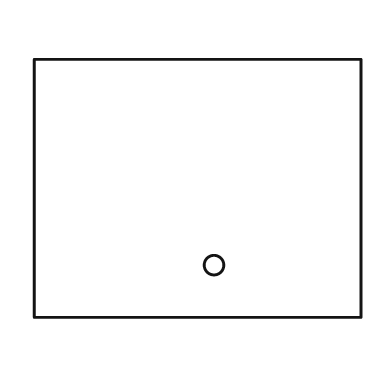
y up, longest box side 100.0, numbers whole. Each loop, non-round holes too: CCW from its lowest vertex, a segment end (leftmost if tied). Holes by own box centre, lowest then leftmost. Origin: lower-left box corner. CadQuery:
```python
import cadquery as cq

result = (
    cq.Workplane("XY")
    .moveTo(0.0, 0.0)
    .lineTo(100.0, 0.0)
    .lineTo(100.0, 79.0)
    .lineTo(0.0, 79.0)
    .close()
    .moveTo(55.0, 16.0)
    .circle(3.0)
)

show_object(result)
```